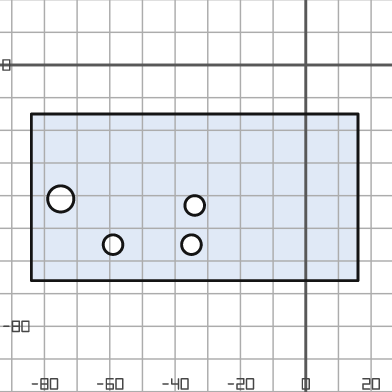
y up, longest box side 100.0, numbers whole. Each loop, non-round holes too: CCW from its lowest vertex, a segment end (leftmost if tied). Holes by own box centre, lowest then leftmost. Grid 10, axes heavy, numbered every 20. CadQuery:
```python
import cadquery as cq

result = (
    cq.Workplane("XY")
    .moveTo(-84.0, -66.0)
    .lineTo(16.0, -66.0)
    .lineTo(16.0, -15.0)
    .lineTo(-84.0, -15.0)
    .close()
    .moveTo(-59.0, -55.0)
    .circle(3.0)
    .moveTo(-35.0, -55.0)
    .circle(3.0)
    .moveTo(-34.0, -43.0)
    .circle(3.0)
    .moveTo(-75.0, -41.0)
    .circle(4.0)
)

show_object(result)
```